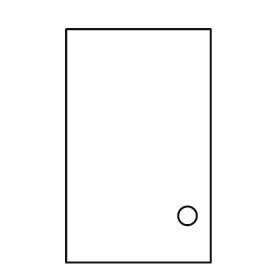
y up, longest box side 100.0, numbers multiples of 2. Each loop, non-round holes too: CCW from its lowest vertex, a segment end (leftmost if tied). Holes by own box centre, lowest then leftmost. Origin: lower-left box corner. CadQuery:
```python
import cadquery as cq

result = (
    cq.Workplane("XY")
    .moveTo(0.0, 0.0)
    .lineTo(62.0, 0.0)
    .lineTo(62.0, 100.0)
    .lineTo(0.0, 100.0)
    .close()
    .moveTo(52.0, 20.0)
    .circle(4.0)
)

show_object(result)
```